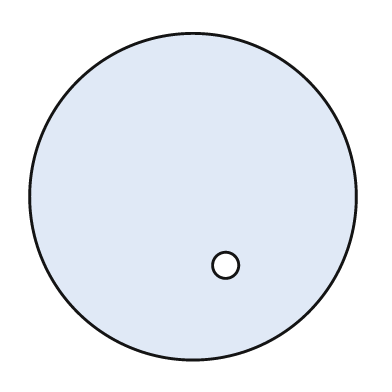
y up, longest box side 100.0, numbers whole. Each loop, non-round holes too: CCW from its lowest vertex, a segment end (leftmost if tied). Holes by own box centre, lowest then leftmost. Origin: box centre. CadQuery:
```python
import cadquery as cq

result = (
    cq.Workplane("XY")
    .moveTo(0.0, 0.0)
    .circle(50.0)
    .moveTo(10.0, -21.0)
    .circle(4.0)
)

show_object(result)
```